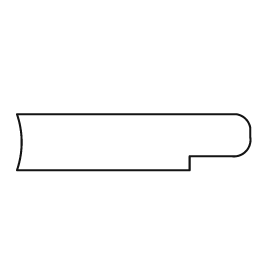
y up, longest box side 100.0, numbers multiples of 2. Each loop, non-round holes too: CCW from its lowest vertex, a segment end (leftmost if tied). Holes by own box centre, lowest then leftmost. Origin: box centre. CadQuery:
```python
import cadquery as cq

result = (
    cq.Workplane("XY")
    .moveTo(-50.0, -12.0)
    .lineTo(24.0, -12.0)
    .lineTo(24.0, -6.0)
    .lineTo(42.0, -6.0)
    .threePointArc((48.0, -4.0), (50.0, 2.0))
    .lineTo(50.0, 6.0)
    .threePointArc((48.0, 10.0), (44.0, 12.0))
    .lineTo(-50.0, 12.0)
    .threePointArc((-48.0, 0.0), (-50.0, -12.0))
    .close()
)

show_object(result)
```